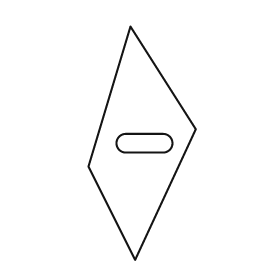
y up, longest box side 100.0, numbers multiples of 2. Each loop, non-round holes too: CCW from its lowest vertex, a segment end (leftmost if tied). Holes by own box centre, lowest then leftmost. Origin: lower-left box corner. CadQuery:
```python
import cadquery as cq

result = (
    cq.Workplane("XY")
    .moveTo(20.0, 0.0)
    .lineTo(46.0, 56.0)
    .lineTo(18.0, 100.0)
    .lineTo(0.0, 40.0)
    .close()
    .moveTo(16.0, 46.0)
    .lineTo(32.0, 46.0)
    .threePointArc((36.0, 50.0), (32.0, 54.0))
    .lineTo(16.0, 54.0)
    .threePointArc((12.0, 50.0), (16.0, 46.0))
    .close()
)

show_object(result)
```